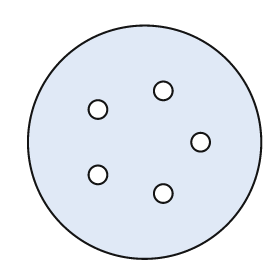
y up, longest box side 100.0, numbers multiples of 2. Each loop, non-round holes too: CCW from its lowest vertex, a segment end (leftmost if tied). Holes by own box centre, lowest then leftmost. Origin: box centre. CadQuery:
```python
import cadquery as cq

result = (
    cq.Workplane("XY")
    .moveTo(0.0, 0.0)
    .circle(50.0)
    .moveTo(8.0, -22.0)
    .circle(4.0)
    .moveTo(-20.0, -14.0)
    .circle(4.0)
    .moveTo(24.0, 0.0)
    .circle(4.0)
    .moveTo(-20.0, 14.0)
    .circle(4.0)
    .moveTo(8.0, 22.0)
    .circle(4.0)
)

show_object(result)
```